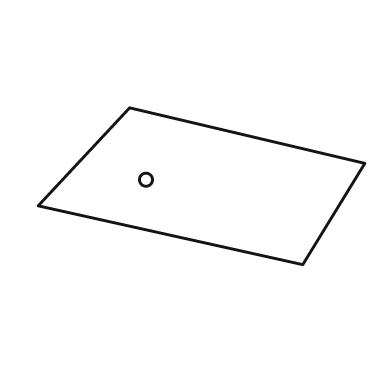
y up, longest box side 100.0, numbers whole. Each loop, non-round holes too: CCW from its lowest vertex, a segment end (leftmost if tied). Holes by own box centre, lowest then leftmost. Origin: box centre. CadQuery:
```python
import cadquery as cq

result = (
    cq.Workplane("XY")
    .moveTo(31.0, -24.0)
    .lineTo(50.0, 7.0)
    .lineTo(-22.0, 24.0)
    .lineTo(-50.0, -6.0)
    .close()
    .moveTo(-17.0, 2.0)
    .circle(2.0)
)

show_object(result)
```